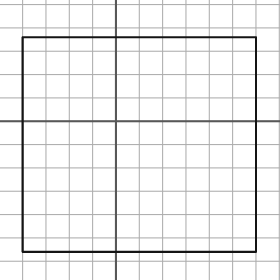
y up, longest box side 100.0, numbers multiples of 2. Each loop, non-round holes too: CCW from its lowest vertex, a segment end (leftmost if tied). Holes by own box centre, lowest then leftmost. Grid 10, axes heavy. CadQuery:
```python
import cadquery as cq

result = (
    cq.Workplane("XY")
    .moveTo(-40.0, -56.0)
    .lineTo(60.0, -56.0)
    .lineTo(60.0, 36.0)
    .lineTo(-40.0, 36.0)
    .close()
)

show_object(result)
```